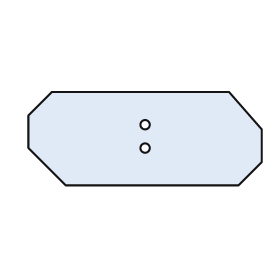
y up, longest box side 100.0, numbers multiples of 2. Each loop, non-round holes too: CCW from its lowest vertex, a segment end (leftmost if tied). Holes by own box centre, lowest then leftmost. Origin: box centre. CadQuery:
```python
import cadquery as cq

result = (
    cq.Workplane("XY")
    .moveTo(-34.0, -20.0)
    .lineTo(40.0, -20.0)
    .lineTo(50.0, -10.0)
    .lineTo(50.0, 4.0)
    .lineTo(36.0, 20.0)
    .lineTo(-40.0, 20.0)
    .lineTo(-50.0, 10.0)
    .lineTo(-50.0, -4.0)
    .close()
    .moveTo(0.0, -4.0)
    .circle(2.0)
    .moveTo(0.0, 6.0)
    .circle(2.0)
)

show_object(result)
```